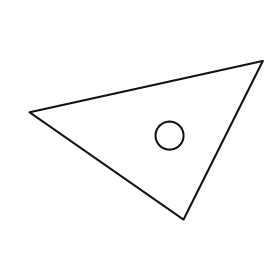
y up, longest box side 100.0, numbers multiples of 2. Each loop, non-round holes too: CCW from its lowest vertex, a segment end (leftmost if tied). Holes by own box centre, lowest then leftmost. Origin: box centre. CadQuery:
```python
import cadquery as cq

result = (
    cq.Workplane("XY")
    .moveTo(16.0, -34.0)
    .lineTo(50.0, 34.0)
    .lineTo(-50.0, 12.0)
    .close()
    .moveTo(10.0, 2.0)
    .circle(6.0)
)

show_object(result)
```